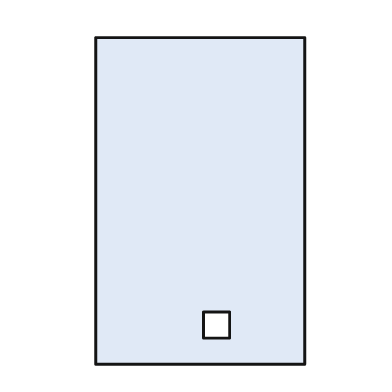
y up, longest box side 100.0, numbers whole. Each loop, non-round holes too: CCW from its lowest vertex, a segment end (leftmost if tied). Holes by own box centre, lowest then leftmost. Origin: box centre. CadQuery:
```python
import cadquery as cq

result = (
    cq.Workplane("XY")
    .moveTo(-32.0, -50.0)
    .lineTo(32.0, -50.0)
    .lineTo(32.0, 50.0)
    .lineTo(-32.0, 50.0)
    .close()
    .moveTo(1.0, -42.0)
    .lineTo(9.0, -42.0)
    .lineTo(9.0, -34.0)
    .lineTo(1.0, -34.0)
    .close()
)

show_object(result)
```